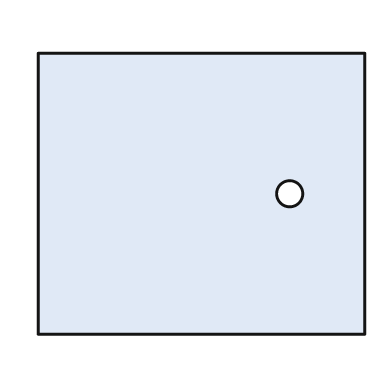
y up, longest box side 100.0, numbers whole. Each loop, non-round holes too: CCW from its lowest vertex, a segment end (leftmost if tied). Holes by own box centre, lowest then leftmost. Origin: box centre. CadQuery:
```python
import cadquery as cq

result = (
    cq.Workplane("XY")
    .moveTo(-50.0, -43.0)
    .lineTo(50.0, -43.0)
    .lineTo(50.0, 43.0)
    .lineTo(-50.0, 43.0)
    .close()
    .moveTo(27.0, 0.0)
    .circle(4.0)
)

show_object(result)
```